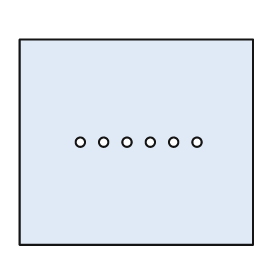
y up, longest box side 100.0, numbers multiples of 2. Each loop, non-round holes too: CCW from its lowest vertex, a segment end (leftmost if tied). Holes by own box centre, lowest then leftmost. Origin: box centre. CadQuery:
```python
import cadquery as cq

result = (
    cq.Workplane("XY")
    .moveTo(-50.0, -44.0)
    .lineTo(50.0, -44.0)
    .lineTo(50.0, 44.0)
    .lineTo(-50.0, 44.0)
    .close()
    .moveTo(-24.0, 0.0)
    .circle(2.0)
    .moveTo(-14.0, 0.0)
    .circle(2.0)
    .moveTo(-4.0, 0.0)
    .circle(2.0)
    .moveTo(6.0, 0.0)
    .circle(2.0)
    .moveTo(16.0, 0.0)
    .circle(2.0)
    .moveTo(26.0, 0.0)
    .circle(2.0)
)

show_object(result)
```